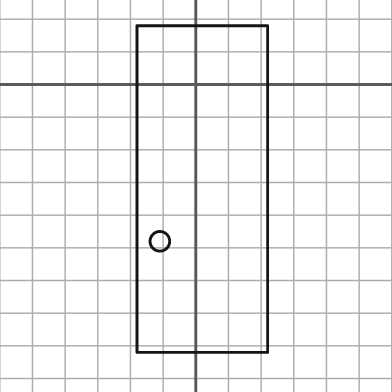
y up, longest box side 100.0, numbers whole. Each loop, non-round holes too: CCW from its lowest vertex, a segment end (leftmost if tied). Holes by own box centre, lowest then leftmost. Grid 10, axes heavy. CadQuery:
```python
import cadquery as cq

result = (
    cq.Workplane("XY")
    .moveTo(-18.0, -82.0)
    .lineTo(22.0, -82.0)
    .lineTo(22.0, 18.0)
    .lineTo(-18.0, 18.0)
    .close()
    .moveTo(-11.0, -48.0)
    .circle(3.0)
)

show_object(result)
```